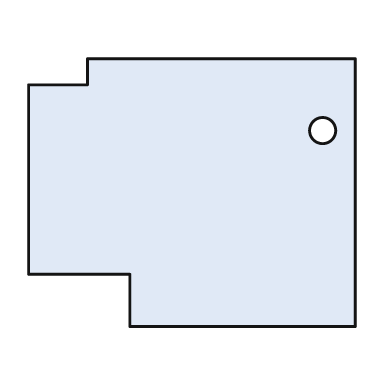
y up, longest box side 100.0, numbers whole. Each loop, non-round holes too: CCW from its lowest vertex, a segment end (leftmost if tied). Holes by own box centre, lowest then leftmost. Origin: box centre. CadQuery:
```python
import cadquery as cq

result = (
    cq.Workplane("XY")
    .moveTo(-19.0, -41.0)
    .lineTo(50.0, -41.0)
    .lineTo(50.0, 41.0)
    .lineTo(-32.0, 41.0)
    .lineTo(-32.0, 33.0)
    .lineTo(-50.0, 33.0)
    .lineTo(-50.0, -25.0)
    .lineTo(-19.0, -25.0)
    .close()
    .moveTo(40.0, 19.0)
    .circle(4.0)
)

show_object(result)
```